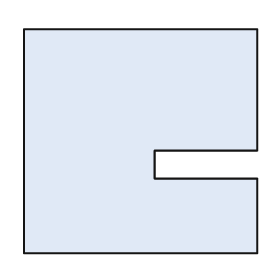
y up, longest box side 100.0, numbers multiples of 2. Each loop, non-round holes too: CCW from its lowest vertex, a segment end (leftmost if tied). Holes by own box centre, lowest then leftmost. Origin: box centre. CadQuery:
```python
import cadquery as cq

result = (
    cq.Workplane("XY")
    .moveTo(-50.0, -48.0)
    .lineTo(50.0, -48.0)
    .lineTo(50.0, -16.0)
    .lineTo(6.0, -16.0)
    .lineTo(6.0, -4.0)
    .lineTo(50.0, -4.0)
    .lineTo(50.0, 48.0)
    .lineTo(-50.0, 48.0)
    .close()
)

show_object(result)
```